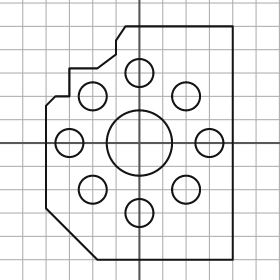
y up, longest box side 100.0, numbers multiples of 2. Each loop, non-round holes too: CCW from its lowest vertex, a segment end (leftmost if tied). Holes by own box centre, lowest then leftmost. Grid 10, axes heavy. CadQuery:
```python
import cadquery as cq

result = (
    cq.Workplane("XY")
    .moveTo(-18.0, -50.0)
    .lineTo(40.0, -50.0)
    .lineTo(40.0, 50.0)
    .lineTo(-6.0, 50.0)
    .lineTo(-10.0, 44.0)
    .lineTo(-10.0, 38.0)
    .lineTo(-18.0, 32.0)
    .lineTo(-30.0, 32.0)
    .lineTo(-30.0, 20.0)
    .lineTo(-36.0, 20.0)
    .lineTo(-40.0, 16.0)
    .lineTo(-40.0, -28.0)
    .close()
    .moveTo(0.0, -30.0)
    .circle(6.0)
    .moveTo(-20.0, -20.0)
    .circle(6.0)
    .moveTo(20.0, -20.0)
    .circle(6.0)
    .moveTo(-30.0, 0.0)
    .circle(6.0)
    .moveTo(0.0, 0.0)
    .circle(14.0)
    .moveTo(30.0, 0.0)
    .circle(6.0)
    .moveTo(-20.0, 20.0)
    .circle(6.0)
    .moveTo(20.0, 20.0)
    .circle(6.0)
    .moveTo(0.0, 30.0)
    .circle(6.0)
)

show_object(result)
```